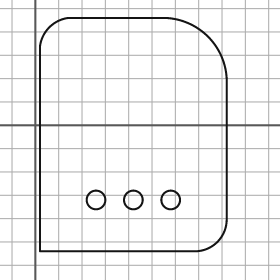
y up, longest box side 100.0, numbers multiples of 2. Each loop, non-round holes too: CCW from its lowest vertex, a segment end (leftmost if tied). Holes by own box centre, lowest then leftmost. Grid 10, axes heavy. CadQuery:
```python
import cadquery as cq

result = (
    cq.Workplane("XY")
    .moveTo(2.0, -54.0)
    .lineTo(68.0, -54.0)
    .threePointArc((78.0, -50.0), (82.0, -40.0))
    .lineTo(82.0, 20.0)
    .threePointArc((74.0, 38.0), (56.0, 46.0))
    .lineTo(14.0, 46.0)
    .threePointArc((6.0, 42.0), (2.0, 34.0))
    .close()
    .moveTo(26.0, -32.0)
    .circle(4.0)
    .moveTo(42.0, -32.0)
    .circle(4.0)
    .moveTo(58.0, -32.0)
    .circle(4.0)
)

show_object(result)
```